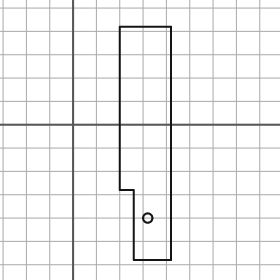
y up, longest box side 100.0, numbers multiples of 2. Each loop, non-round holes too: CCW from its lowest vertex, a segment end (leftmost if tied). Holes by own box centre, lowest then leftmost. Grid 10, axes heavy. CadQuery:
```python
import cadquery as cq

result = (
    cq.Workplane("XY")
    .moveTo(26.0, -58.0)
    .lineTo(42.0, -58.0)
    .lineTo(42.0, 42.0)
    .lineTo(20.0, 42.0)
    .lineTo(20.0, -28.0)
    .lineTo(26.0, -28.0)
    .close()
    .moveTo(32.0, -40.0)
    .circle(2.0)
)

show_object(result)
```